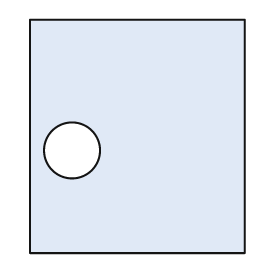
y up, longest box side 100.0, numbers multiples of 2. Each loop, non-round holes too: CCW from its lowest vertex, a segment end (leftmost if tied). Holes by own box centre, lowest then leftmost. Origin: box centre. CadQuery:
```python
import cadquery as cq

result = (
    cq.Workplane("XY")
    .moveTo(-46.0, -50.0)
    .lineTo(46.0, -50.0)
    .lineTo(46.0, 50.0)
    .lineTo(-46.0, 50.0)
    .close()
    .moveTo(-28.0, -6.0)
    .circle(12.0)
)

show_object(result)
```